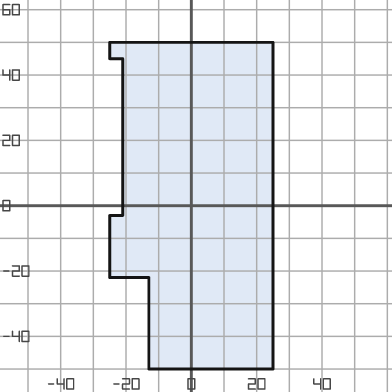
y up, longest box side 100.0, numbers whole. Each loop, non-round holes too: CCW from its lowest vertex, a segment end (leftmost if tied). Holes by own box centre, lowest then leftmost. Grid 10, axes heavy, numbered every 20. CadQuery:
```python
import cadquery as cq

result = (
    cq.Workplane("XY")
    .moveTo(-13.0, -50.0)
    .lineTo(25.0, -50.0)
    .lineTo(25.0, 50.0)
    .lineTo(-25.0, 50.0)
    .lineTo(-25.0, 45.0)
    .lineTo(-21.0, 45.0)
    .lineTo(-21.0, -3.0)
    .lineTo(-25.0, -3.0)
    .lineTo(-25.0, -22.0)
    .lineTo(-13.0, -22.0)
    .close()
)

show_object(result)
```